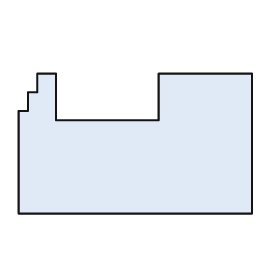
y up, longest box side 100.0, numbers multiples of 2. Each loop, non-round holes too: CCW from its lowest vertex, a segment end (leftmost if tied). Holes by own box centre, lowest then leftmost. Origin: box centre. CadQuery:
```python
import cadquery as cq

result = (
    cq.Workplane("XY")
    .moveTo(-50.0, -30.0)
    .lineTo(50.0, -30.0)
    .lineTo(50.0, 30.0)
    .lineTo(10.0, 30.0)
    .lineTo(10.0, 10.0)
    .lineTo(-34.0, 10.0)
    .lineTo(-34.0, 30.0)
    .lineTo(-42.0, 30.0)
    .lineTo(-42.0, 22.0)
    .lineTo(-46.0, 22.0)
    .lineTo(-46.0, 14.0)
    .lineTo(-50.0, 14.0)
    .close()
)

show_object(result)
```